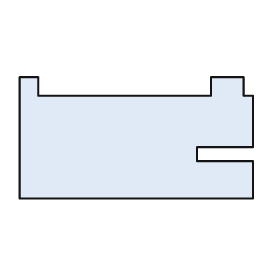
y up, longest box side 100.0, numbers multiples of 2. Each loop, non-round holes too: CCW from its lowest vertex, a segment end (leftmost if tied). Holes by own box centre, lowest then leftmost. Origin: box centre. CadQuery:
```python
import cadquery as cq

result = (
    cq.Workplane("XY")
    .moveTo(-50.0, -26.0)
    .lineTo(50.0, -26.0)
    .lineTo(50.0, -10.0)
    .lineTo(26.0, -10.0)
    .lineTo(26.0, -4.0)
    .lineTo(50.0, -4.0)
    .lineTo(50.0, 18.0)
    .lineTo(46.0, 18.0)
    .lineTo(46.0, 26.0)
    .lineTo(32.0, 26.0)
    .lineTo(32.0, 18.0)
    .lineTo(-42.0, 18.0)
    .lineTo(-42.0, 26.0)
    .lineTo(-50.0, 26.0)
    .close()
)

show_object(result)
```